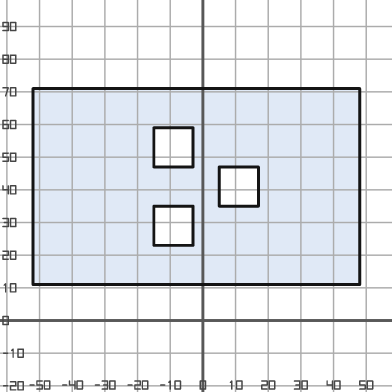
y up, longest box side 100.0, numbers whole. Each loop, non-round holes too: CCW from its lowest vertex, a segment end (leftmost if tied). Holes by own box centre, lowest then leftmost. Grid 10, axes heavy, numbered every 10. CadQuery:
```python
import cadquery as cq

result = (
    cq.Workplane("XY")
    .moveTo(-52.0, 11.0)
    .lineTo(48.0, 11.0)
    .lineTo(48.0, 71.0)
    .lineTo(-52.0, 71.0)
    .close()
    .moveTo(-15.0, 23.0)
    .lineTo(-3.0, 23.0)
    .lineTo(-3.0, 35.0)
    .lineTo(-15.0, 35.0)
    .close()
    .moveTo(5.0, 35.0)
    .lineTo(17.0, 35.0)
    .lineTo(17.0, 47.0)
    .lineTo(5.0, 47.0)
    .close()
    .moveTo(-15.0, 47.0)
    .lineTo(-3.0, 47.0)
    .lineTo(-3.0, 59.0)
    .lineTo(-15.0, 59.0)
    .close()
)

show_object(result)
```